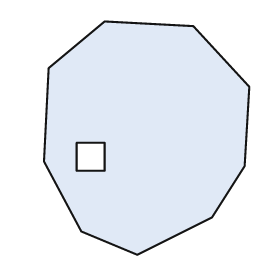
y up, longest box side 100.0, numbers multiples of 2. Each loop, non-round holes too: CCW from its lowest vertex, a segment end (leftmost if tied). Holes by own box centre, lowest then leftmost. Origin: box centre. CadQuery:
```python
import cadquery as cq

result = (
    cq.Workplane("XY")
    .moveTo(-4.0, -50.0)
    .lineTo(28.0, -34.0)
    .lineTo(42.0, -12.0)
    .lineTo(44.0, 22.0)
    .lineTo(20.0, 48.0)
    .lineTo(-18.0, 50.0)
    .lineTo(-42.0, 30.0)
    .lineTo(-44.0, -10.0)
    .lineTo(-28.0, -40.0)
    .close()
    .moveTo(-30.0, -14.0)
    .lineTo(-18.0, -14.0)
    .lineTo(-18.0, -2.0)
    .lineTo(-30.0, -2.0)
    .close()
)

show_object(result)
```